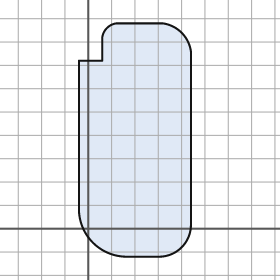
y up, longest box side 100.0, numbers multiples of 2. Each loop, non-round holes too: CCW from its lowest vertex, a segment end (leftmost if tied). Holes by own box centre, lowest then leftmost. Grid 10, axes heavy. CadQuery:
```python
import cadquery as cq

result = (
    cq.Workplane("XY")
    .moveTo(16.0, -12.0)
    .lineTo(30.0, -12.0)
    .threePointArc((40.0, -8.0), (44.0, 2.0))
    .lineTo(44.0, 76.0)
    .threePointArc((40.0, 84.0), (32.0, 88.0))
    .lineTo(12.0, 88.0)
    .threePointArc((8.0, 86.0), (6.0, 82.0))
    .lineTo(6.0, 72.0)
    .lineTo(-4.0, 72.0)
    .lineTo(-4.0, 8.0)
    .threePointArc((2.0, -6.0), (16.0, -12.0))
    .close()
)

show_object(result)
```